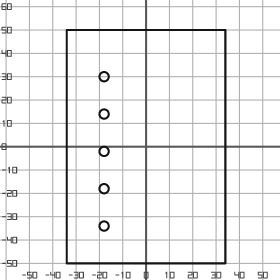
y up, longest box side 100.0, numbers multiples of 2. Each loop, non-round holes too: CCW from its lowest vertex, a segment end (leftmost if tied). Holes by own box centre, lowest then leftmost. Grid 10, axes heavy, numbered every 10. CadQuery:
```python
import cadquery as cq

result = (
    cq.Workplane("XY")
    .moveTo(-34.0, -50.0)
    .lineTo(34.0, -50.0)
    .lineTo(34.0, 50.0)
    .lineTo(-34.0, 50.0)
    .close()
    .moveTo(-18.0, -34.0)
    .circle(2.0)
    .moveTo(-18.0, -18.0)
    .circle(2.0)
    .moveTo(-18.0, -2.0)
    .circle(2.0)
    .moveTo(-18.0, 14.0)
    .circle(2.0)
    .moveTo(-18.0, 30.0)
    .circle(2.0)
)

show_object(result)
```